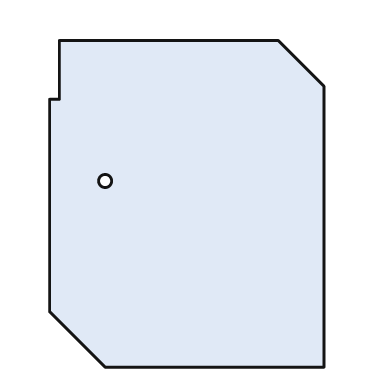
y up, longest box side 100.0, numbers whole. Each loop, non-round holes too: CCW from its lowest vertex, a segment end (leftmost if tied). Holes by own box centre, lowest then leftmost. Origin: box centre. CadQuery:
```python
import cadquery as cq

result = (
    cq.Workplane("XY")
    .moveTo(-25.0, -50.0)
    .lineTo(42.0, -50.0)
    .lineTo(42.0, 36.0)
    .lineTo(28.0, 50.0)
    .lineTo(-39.0, 50.0)
    .lineTo(-39.0, 32.0)
    .lineTo(-42.0, 32.0)
    .lineTo(-42.0, -33.0)
    .close()
    .moveTo(-25.0, 7.0)
    .circle(2.0)
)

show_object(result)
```